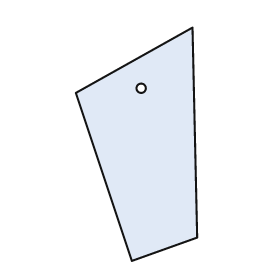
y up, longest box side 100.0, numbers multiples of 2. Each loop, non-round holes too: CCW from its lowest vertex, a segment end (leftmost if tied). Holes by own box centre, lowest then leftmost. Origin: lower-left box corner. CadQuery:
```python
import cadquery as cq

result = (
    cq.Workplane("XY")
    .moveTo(24.0, 0.0)
    .lineTo(52.0, 10.0)
    .lineTo(50.0, 100.0)
    .lineTo(0.0, 72.0)
    .close()
    .moveTo(28.0, 74.0)
    .circle(2.0)
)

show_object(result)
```